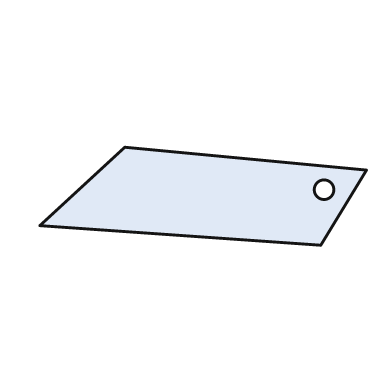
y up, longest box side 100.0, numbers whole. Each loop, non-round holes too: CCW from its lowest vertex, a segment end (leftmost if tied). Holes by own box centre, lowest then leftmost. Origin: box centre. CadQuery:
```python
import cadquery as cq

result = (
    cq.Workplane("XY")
    .moveTo(36.0, -15.0)
    .lineTo(50.0, 8.0)
    .lineTo(-24.0, 15.0)
    .lineTo(-50.0, -9.0)
    .close()
    .moveTo(37.0, 2.0)
    .circle(3.0)
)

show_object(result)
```